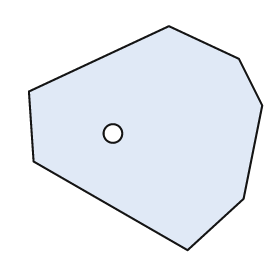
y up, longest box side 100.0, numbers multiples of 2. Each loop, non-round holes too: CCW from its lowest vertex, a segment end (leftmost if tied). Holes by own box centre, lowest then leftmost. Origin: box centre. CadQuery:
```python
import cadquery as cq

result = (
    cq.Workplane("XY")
    .moveTo(18.0, -48.0)
    .lineTo(42.0, -26.0)
    .lineTo(50.0, 14.0)
    .lineTo(40.0, 34.0)
    .lineTo(10.0, 48.0)
    .lineTo(-50.0, 20.0)
    .lineTo(-48.0, -10.0)
    .close()
    .moveTo(-14.0, 2.0)
    .circle(4.0)
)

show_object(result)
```